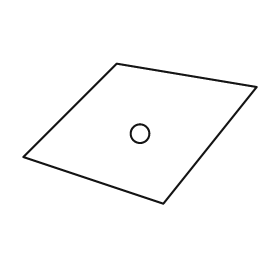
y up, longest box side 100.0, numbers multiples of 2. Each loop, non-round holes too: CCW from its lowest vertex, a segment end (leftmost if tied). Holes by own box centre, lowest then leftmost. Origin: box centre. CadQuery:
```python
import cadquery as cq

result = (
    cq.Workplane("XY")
    .moveTo(10.0, -30.0)
    .lineTo(50.0, 20.0)
    .lineTo(-10.0, 30.0)
    .lineTo(-50.0, -10.0)
    .close()
    .moveTo(0.0, 0.0)
    .circle(4.0)
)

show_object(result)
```